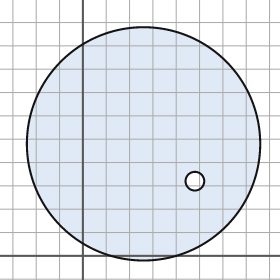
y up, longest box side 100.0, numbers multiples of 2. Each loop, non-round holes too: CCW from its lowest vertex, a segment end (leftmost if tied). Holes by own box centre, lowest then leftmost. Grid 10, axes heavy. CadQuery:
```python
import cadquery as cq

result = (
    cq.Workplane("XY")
    .moveTo(26.0, 48.0)
    .circle(50.0)
    .moveTo(48.0, 32.0)
    .circle(4.0)
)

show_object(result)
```